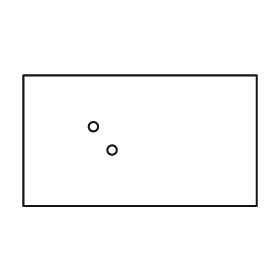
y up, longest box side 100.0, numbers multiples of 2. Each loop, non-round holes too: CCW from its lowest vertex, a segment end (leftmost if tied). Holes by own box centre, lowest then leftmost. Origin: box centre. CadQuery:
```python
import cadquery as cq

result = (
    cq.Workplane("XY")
    .moveTo(-50.0, -28.0)
    .lineTo(50.0, -28.0)
    .lineTo(50.0, 28.0)
    .lineTo(-50.0, 28.0)
    .close()
    .moveTo(-12.0, -4.0)
    .circle(2.0)
    .moveTo(-20.0, 6.0)
    .circle(2.0)
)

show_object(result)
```